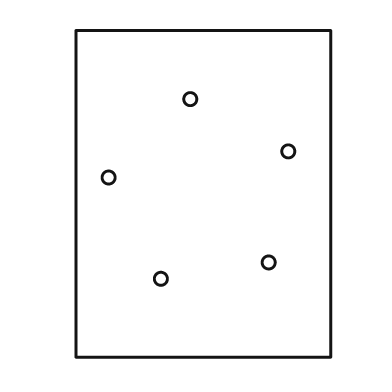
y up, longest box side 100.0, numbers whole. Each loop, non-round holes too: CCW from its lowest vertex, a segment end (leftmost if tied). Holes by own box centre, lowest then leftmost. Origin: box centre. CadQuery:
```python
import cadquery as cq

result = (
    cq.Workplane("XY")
    .moveTo(-39.0, -50.0)
    .lineTo(39.0, -50.0)
    .lineTo(39.0, 50.0)
    .lineTo(-39.0, 50.0)
    .close()
    .moveTo(-13.0, -26.0)
    .circle(2.0)
    .moveTo(20.0, -21.0)
    .circle(2.0)
    .moveTo(-29.0, 5.0)
    .circle(2.0)
    .moveTo(26.0, 13.0)
    .circle(2.0)
    .moveTo(-4.0, 29.0)
    .circle(2.0)
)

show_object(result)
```